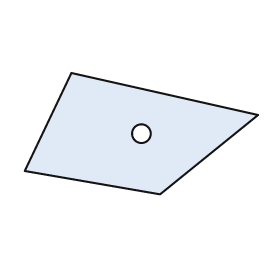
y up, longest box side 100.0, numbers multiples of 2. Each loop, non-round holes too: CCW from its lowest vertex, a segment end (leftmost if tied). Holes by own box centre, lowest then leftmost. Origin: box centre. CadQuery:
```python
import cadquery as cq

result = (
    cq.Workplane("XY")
    .moveTo(8.0, -26.0)
    .lineTo(50.0, 8.0)
    .lineTo(-30.0, 26.0)
    .lineTo(-50.0, -16.0)
    .close()
    .moveTo(0.0, 0.0)
    .circle(4.0)
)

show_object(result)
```